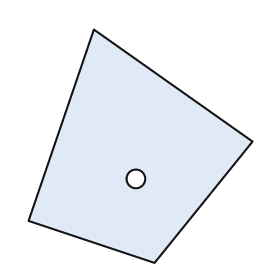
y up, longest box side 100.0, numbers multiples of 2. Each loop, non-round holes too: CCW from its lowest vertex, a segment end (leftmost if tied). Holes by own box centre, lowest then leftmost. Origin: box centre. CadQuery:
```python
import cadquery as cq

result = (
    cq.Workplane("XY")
    .moveTo(6.0, -50.0)
    .lineTo(48.0, 2.0)
    .lineTo(-20.0, 50.0)
    .lineTo(-48.0, -32.0)
    .close()
    .moveTo(-2.0, -14.0)
    .circle(4.0)
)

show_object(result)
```